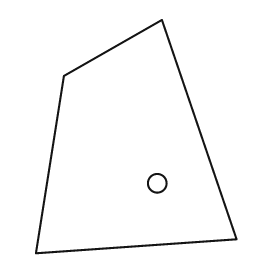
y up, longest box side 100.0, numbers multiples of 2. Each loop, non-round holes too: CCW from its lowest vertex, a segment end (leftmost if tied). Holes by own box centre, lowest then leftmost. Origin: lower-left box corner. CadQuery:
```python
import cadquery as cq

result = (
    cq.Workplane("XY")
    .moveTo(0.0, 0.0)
    .lineTo(86.0, 6.0)
    .lineTo(54.0, 100.0)
    .lineTo(12.0, 76.0)
    .close()
    .moveTo(52.0, 30.0)
    .circle(4.0)
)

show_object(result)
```